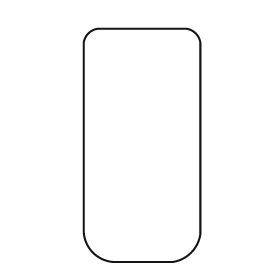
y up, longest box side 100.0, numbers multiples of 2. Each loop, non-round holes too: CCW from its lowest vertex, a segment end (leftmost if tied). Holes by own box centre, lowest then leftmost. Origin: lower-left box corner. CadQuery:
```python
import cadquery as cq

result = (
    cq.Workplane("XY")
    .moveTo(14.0, 0.0)
    .lineTo(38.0, 0.0)
    .threePointArc((46.0, 4.0), (50.0, 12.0))
    .lineTo(50.0, 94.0)
    .threePointArc((48.0, 98.0), (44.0, 100.0))
    .lineTo(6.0, 100.0)
    .threePointArc((2.0, 98.0), (0.0, 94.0))
    .lineTo(0.0, 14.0)
    .threePointArc((4.0, 4.0), (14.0, 0.0))
    .close()
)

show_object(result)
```